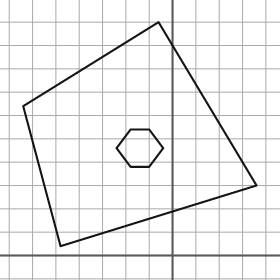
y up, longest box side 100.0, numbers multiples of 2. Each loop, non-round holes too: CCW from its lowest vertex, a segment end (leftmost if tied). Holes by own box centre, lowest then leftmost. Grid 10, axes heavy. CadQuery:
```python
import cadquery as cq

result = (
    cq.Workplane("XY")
    .moveTo(-48.0, 4.0)
    .lineTo(36.0, 30.0)
    .lineTo(-6.0, 100.0)
    .lineTo(-64.0, 64.0)
    .close()
    .moveTo(-18.0, 38.0)
    .lineTo(-10.0, 38.0)
    .lineTo(-4.0, 46.0)
    .lineTo(-10.0, 54.0)
    .lineTo(-18.0, 54.0)
    .lineTo(-24.0, 46.0)
    .close()
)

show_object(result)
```